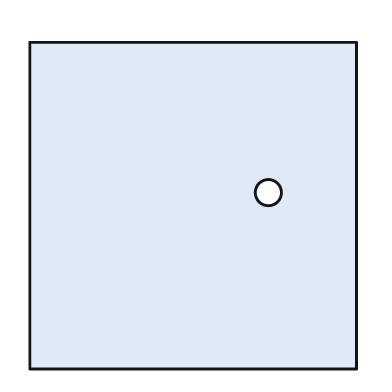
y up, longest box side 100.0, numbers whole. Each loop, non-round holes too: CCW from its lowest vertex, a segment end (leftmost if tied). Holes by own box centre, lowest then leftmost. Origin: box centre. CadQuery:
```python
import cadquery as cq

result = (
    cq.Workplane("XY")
    .moveTo(-50.0, -50.0)
    .lineTo(50.0, -50.0)
    .lineTo(50.0, 50.0)
    .lineTo(-50.0, 50.0)
    .close()
    .moveTo(23.0, 4.0)
    .circle(4.0)
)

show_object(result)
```